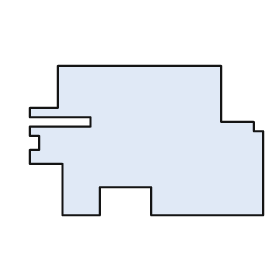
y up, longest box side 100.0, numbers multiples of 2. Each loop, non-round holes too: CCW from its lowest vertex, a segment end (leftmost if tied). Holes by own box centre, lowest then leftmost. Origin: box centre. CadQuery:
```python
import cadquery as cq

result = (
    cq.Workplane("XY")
    .moveTo(-36.0, -32.0)
    .lineTo(-20.0, -32.0)
    .lineTo(-20.0, -20.0)
    .lineTo(2.0, -20.0)
    .lineTo(2.0, -32.0)
    .lineTo(50.0, -32.0)
    .lineTo(50.0, 4.0)
    .lineTo(46.0, 4.0)
    .lineTo(46.0, 8.0)
    .lineTo(32.0, 8.0)
    .lineTo(32.0, 32.0)
    .lineTo(-38.0, 32.0)
    .lineTo(-38.0, 14.0)
    .lineTo(-50.0, 14.0)
    .lineTo(-50.0, 10.0)
    .lineTo(-24.0, 10.0)
    .lineTo(-24.0, 6.0)
    .lineTo(-50.0, 6.0)
    .lineTo(-50.0, 2.0)
    .lineTo(-46.0, 2.0)
    .lineTo(-46.0, -4.0)
    .lineTo(-50.0, -4.0)
    .lineTo(-50.0, -10.0)
    .lineTo(-36.0, -10.0)
    .close()
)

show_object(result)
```